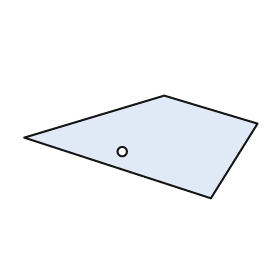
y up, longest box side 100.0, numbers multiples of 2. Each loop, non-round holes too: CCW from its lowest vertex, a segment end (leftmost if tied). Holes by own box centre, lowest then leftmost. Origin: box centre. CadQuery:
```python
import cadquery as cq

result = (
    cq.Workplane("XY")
    .moveTo(30.0, -22.0)
    .lineTo(50.0, 10.0)
    .lineTo(10.0, 22.0)
    .lineTo(-50.0, 4.0)
    .close()
    .moveTo(-8.0, -2.0)
    .circle(2.0)
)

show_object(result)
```